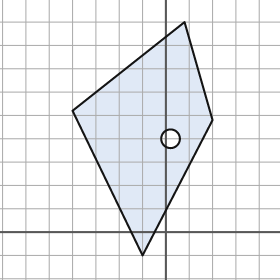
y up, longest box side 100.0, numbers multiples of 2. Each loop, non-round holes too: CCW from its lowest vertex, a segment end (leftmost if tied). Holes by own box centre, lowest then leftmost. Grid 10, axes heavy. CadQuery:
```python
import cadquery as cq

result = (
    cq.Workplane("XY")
    .moveTo(-10.0, -10.0)
    .lineTo(20.0, 48.0)
    .lineTo(8.0, 90.0)
    .lineTo(-40.0, 52.0)
    .close()
    .moveTo(2.0, 40.0)
    .circle(4.0)
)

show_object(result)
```